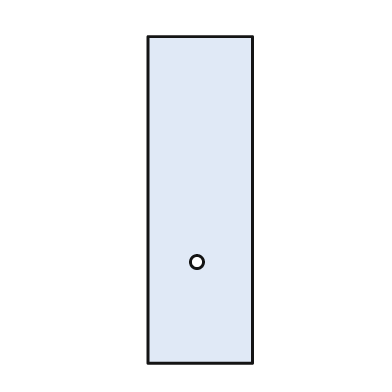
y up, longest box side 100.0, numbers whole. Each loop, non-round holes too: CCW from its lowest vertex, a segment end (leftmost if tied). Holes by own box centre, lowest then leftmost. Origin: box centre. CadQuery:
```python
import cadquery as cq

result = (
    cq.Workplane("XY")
    .moveTo(-16.0, -50.0)
    .lineTo(16.0, -50.0)
    .lineTo(16.0, 50.0)
    .lineTo(-16.0, 50.0)
    .close()
    .moveTo(-1.0, -19.0)
    .circle(2.0)
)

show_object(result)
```